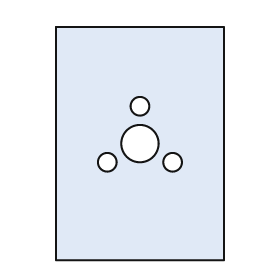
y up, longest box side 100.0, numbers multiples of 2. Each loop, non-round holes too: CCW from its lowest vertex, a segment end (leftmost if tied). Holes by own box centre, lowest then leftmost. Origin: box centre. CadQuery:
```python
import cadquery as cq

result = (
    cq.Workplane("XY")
    .moveTo(-36.0, -50.0)
    .lineTo(36.0, -50.0)
    .lineTo(36.0, 50.0)
    .lineTo(-36.0, 50.0)
    .close()
    .moveTo(-14.0, -8.0)
    .circle(4.0)
    .moveTo(14.0, -8.0)
    .circle(4.0)
    .moveTo(0.0, 0.0)
    .circle(8.0)
    .moveTo(0.0, 16.0)
    .circle(4.0)
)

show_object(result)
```